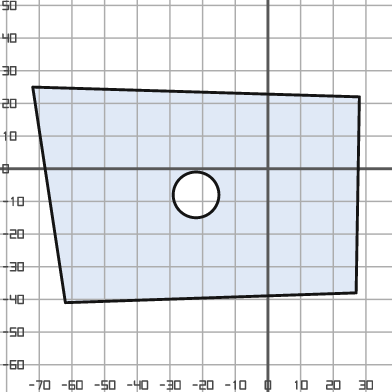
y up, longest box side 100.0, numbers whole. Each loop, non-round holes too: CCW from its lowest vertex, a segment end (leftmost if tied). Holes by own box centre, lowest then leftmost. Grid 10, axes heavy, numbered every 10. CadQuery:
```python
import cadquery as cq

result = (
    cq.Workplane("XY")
    .moveTo(-62.0, -41.0)
    .lineTo(27.0, -38.0)
    .lineTo(28.0, 22.0)
    .lineTo(-72.0, 25.0)
    .close()
    .moveTo(-22.0, -8.0)
    .circle(7.0)
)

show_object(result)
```